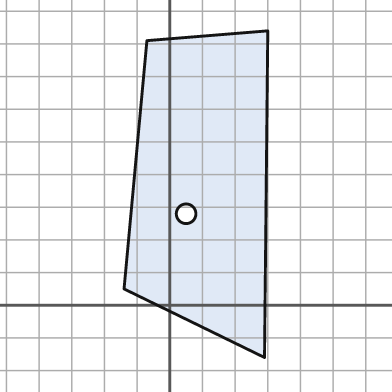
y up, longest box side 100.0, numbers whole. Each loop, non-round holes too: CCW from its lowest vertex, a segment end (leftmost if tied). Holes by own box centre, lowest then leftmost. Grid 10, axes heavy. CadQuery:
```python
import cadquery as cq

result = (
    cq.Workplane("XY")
    .moveTo(29.0, -16.0)
    .lineTo(30.0, 84.0)
    .lineTo(-7.0, 81.0)
    .lineTo(-14.0, 5.0)
    .close()
    .moveTo(5.0, 28.0)
    .circle(3.0)
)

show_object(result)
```